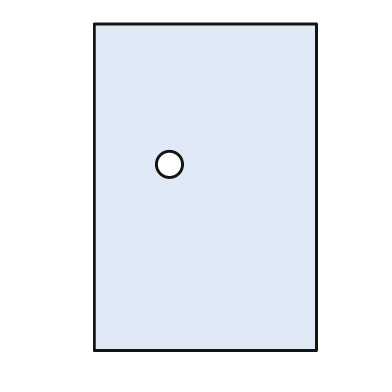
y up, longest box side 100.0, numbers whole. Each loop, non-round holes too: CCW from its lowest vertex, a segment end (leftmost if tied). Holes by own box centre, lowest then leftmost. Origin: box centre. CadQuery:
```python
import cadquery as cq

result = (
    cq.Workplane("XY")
    .moveTo(-34.0, -50.0)
    .lineTo(34.0, -50.0)
    .lineTo(34.0, 50.0)
    .lineTo(-34.0, 50.0)
    .close()
    .moveTo(-11.0, 7.0)
    .circle(4.0)
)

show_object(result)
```